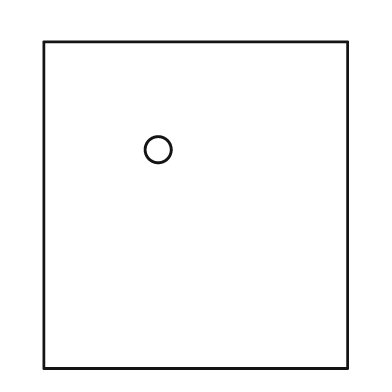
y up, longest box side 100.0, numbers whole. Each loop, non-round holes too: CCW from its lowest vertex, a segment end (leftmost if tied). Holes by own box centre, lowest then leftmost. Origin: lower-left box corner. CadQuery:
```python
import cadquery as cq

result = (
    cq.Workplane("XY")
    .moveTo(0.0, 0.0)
    .lineTo(93.0, 0.0)
    .lineTo(93.0, 100.0)
    .lineTo(0.0, 100.0)
    .close()
    .moveTo(35.0, 67.0)
    .circle(4.0)
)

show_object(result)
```